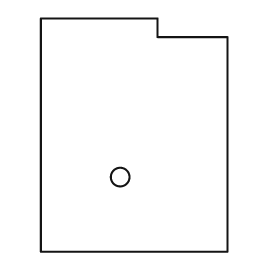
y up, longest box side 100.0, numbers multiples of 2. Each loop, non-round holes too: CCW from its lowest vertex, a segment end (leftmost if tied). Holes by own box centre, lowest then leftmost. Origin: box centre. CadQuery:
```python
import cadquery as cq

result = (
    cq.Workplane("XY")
    .moveTo(-40.0, -50.0)
    .lineTo(40.0, -50.0)
    .lineTo(40.0, 42.0)
    .lineTo(10.0, 42.0)
    .lineTo(10.0, 50.0)
    .lineTo(-40.0, 50.0)
    .close()
    .moveTo(-6.0, -18.0)
    .circle(4.0)
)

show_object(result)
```